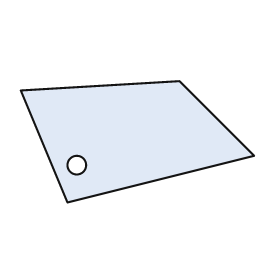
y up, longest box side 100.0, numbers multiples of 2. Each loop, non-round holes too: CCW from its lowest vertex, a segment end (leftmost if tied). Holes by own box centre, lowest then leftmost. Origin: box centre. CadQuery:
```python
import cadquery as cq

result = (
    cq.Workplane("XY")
    .moveTo(-30.0, -26.0)
    .lineTo(50.0, -6.0)
    .lineTo(18.0, 26.0)
    .lineTo(-50.0, 22.0)
    .close()
    .moveTo(-26.0, -10.0)
    .circle(4.0)
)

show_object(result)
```